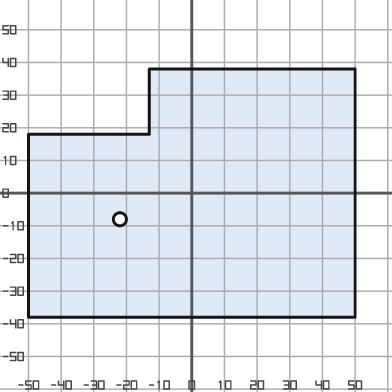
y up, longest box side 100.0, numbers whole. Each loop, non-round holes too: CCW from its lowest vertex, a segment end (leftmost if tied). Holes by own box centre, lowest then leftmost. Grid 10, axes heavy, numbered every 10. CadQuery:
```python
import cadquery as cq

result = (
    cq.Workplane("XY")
    .moveTo(-50.0, -38.0)
    .lineTo(50.0, -38.0)
    .lineTo(50.0, 38.0)
    .lineTo(-13.0, 38.0)
    .lineTo(-13.0, 18.0)
    .lineTo(-50.0, 18.0)
    .close()
    .moveTo(-22.0, -8.0)
    .circle(2.0)
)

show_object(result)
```